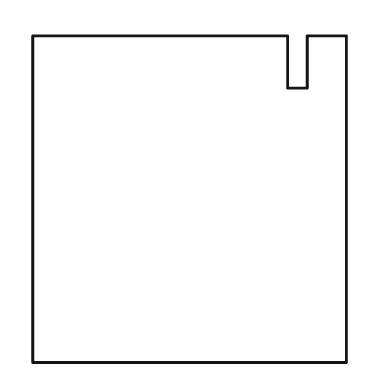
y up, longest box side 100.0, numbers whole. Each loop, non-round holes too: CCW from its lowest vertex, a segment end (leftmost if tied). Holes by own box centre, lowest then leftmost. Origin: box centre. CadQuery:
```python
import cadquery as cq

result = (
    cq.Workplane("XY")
    .moveTo(-48.0, -50.0)
    .lineTo(48.0, -50.0)
    .lineTo(48.0, 50.0)
    .lineTo(36.0, 50.0)
    .lineTo(36.0, 34.0)
    .lineTo(30.0, 34.0)
    .lineTo(30.0, 50.0)
    .lineTo(-48.0, 50.0)
    .close()
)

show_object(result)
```